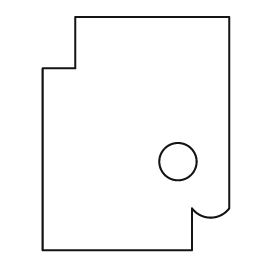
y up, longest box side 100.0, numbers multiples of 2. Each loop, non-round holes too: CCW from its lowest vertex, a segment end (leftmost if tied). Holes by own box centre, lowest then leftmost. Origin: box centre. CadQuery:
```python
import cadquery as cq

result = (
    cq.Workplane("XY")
    .moveTo(-40.0, -50.0)
    .lineTo(24.0, -50.0)
    .lineTo(24.0, -32.0)
    .threePointArc((32.0, -36.0), (40.0, -32.0))
    .lineTo(40.0, 50.0)
    .lineTo(-26.0, 50.0)
    .lineTo(-26.0, 28.0)
    .lineTo(-40.0, 28.0)
    .close()
    .moveTo(18.0, -12.0)
    .circle(8.0)
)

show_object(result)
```